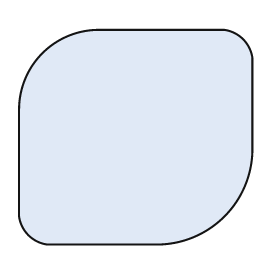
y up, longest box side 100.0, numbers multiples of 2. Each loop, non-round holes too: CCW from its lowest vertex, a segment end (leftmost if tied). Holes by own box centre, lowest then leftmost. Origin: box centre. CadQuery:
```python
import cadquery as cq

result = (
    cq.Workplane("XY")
    .moveTo(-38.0, -46.0)
    .lineTo(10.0, -46.0)
    .threePointArc((38.0, -34.0), (50.0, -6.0))
    .lineTo(50.0, 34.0)
    .threePointArc((46.0, 42.0), (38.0, 46.0))
    .lineTo(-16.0, 46.0)
    .threePointArc((-40.0, 36.0), (-50.0, 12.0))
    .lineTo(-50.0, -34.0)
    .threePointArc((-46.0, -42.0), (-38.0, -46.0))
    .close()
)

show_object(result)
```